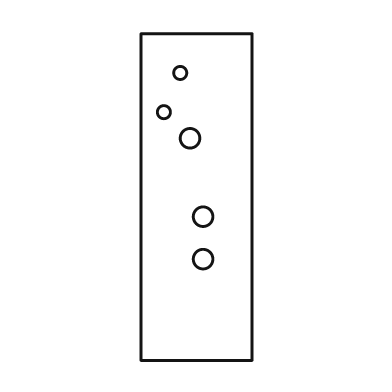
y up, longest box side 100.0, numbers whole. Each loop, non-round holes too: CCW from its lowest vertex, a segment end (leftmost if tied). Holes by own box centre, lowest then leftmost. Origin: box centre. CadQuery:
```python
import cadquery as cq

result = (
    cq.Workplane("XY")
    .moveTo(-17.0, -50.0)
    .lineTo(17.0, -50.0)
    .lineTo(17.0, 50.0)
    .lineTo(-17.0, 50.0)
    .close()
    .moveTo(2.0, -19.0)
    .circle(3.0)
    .moveTo(2.0, -6.0)
    .circle(3.0)
    .moveTo(-2.0, 18.0)
    .circle(3.0)
    .moveTo(-10.0, 26.0)
    .circle(2.0)
    .moveTo(-5.0, 38.0)
    .circle(2.0)
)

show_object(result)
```